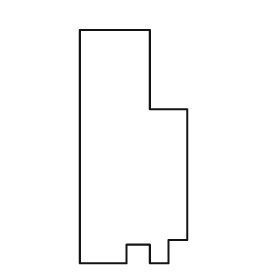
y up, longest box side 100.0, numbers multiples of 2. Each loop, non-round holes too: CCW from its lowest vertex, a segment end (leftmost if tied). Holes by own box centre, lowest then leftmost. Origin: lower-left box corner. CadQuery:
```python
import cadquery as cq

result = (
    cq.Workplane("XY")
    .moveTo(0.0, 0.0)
    .lineTo(20.0, 0.0)
    .lineTo(20.0, 8.0)
    .lineTo(30.0, 8.0)
    .lineTo(30.0, 0.0)
    .lineTo(38.0, 0.0)
    .lineTo(38.0, 10.0)
    .lineTo(46.0, 10.0)
    .lineTo(46.0, 66.0)
    .lineTo(30.0, 66.0)
    .lineTo(30.0, 100.0)
    .lineTo(0.0, 100.0)
    .close()
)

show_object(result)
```